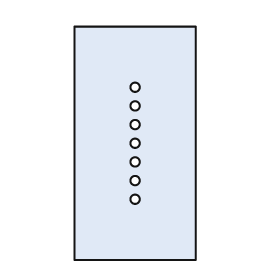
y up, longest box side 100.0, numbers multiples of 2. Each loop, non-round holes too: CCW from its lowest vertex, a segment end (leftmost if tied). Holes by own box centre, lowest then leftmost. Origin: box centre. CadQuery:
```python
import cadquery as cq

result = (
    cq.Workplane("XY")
    .moveTo(-26.0, -50.0)
    .lineTo(26.0, -50.0)
    .lineTo(26.0, 50.0)
    .lineTo(-26.0, 50.0)
    .close()
    .moveTo(0.0, -24.0)
    .circle(2.0)
    .moveTo(0.0, -16.0)
    .circle(2.0)
    .moveTo(0.0, -8.0)
    .circle(2.0)
    .moveTo(0.0, 0.0)
    .circle(2.0)
    .moveTo(0.0, 8.0)
    .circle(2.0)
    .moveTo(0.0, 16.0)
    .circle(2.0)
    .moveTo(0.0, 24.0)
    .circle(2.0)
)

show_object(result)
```